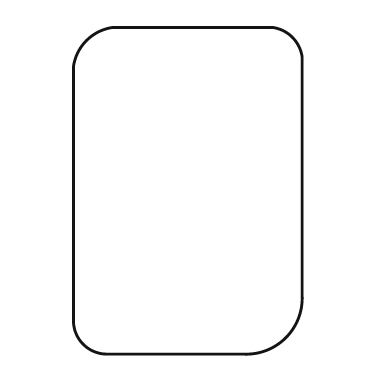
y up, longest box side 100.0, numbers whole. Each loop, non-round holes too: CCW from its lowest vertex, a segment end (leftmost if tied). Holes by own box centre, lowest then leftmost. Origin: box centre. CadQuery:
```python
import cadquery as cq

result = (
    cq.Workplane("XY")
    .moveTo(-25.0, -50.0)
    .lineTo(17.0, -50.0)
    .threePointArc((30.0, -45.0), (35.0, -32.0))
    .lineTo(35.0, 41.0)
    .threePointArc((32.0, 47.0), (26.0, 50.0))
    .lineTo(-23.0, 50.0)
    .threePointArc((-31.0, 46.0), (-35.0, 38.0))
    .lineTo(-35.0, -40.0)
    .threePointArc((-32.0, -47.0), (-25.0, -50.0))
    .close()
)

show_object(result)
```